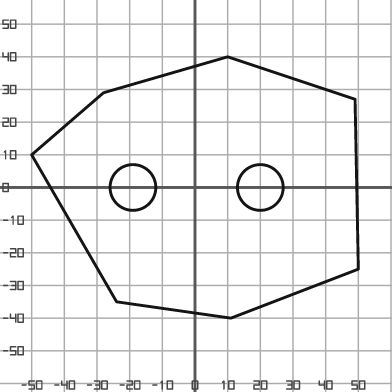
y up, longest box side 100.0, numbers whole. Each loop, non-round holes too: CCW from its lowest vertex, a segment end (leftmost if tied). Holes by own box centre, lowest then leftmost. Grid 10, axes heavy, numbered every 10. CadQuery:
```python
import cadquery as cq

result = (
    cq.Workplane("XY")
    .moveTo(11.0, -40.0)
    .lineTo(50.0, -25.0)
    .lineTo(49.0, 27.0)
    .lineTo(10.0, 40.0)
    .lineTo(-28.0, 29.0)
    .lineTo(-50.0, 10.0)
    .lineTo(-24.0, -35.0)
    .close()
    .moveTo(-19.0, 0.0)
    .circle(7.0)
    .moveTo(20.0, 0.0)
    .circle(7.0)
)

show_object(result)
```